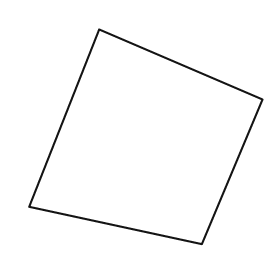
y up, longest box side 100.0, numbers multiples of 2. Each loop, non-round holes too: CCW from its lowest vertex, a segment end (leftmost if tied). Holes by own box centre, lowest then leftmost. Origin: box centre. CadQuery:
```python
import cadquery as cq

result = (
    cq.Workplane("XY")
    .moveTo(24.0, -46.0)
    .lineTo(50.0, 16.0)
    .lineTo(-20.0, 46.0)
    .lineTo(-50.0, -30.0)
    .close()
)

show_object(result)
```